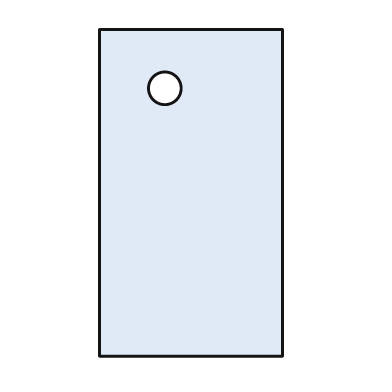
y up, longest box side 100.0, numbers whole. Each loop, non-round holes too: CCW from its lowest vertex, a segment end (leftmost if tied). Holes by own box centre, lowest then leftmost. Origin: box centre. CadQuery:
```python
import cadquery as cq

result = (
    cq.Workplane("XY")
    .moveTo(-28.0, -50.0)
    .lineTo(28.0, -50.0)
    .lineTo(28.0, 50.0)
    .lineTo(-28.0, 50.0)
    .close()
    .moveTo(-8.0, 32.0)
    .circle(5.0)
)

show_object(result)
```